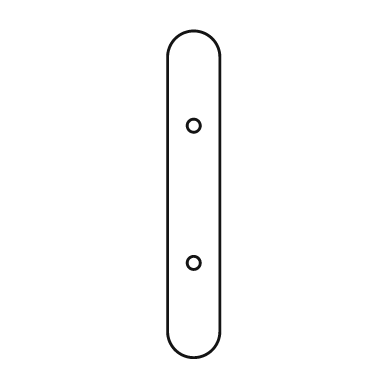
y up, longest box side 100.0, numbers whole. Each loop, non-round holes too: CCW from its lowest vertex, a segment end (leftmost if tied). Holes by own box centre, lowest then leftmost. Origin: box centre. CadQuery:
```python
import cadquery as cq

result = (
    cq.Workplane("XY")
    .moveTo(-8.0, -42.0)
    .threePointArc((0.0, -50.0), (8.0, -42.0))
    .lineTo(8.0, 42.0)
    .threePointArc((0.0, 50.0), (-8.0, 42.0))
    .close()
    .moveTo(0.0, -21.0)
    .circle(2.0)
    .moveTo(0.0, 21.0)
    .circle(2.0)
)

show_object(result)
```